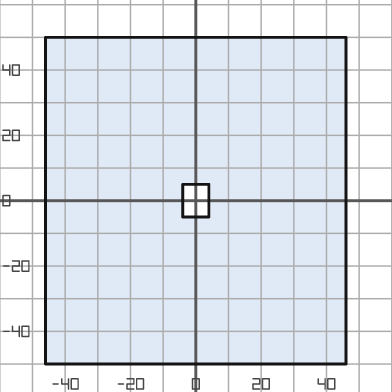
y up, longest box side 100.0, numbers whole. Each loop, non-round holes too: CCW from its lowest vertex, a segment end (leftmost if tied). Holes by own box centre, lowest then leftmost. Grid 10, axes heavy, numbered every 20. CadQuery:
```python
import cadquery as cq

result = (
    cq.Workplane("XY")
    .moveTo(-46.0, -50.0)
    .lineTo(46.0, -50.0)
    .lineTo(46.0, 50.0)
    .lineTo(-46.0, 50.0)
    .close()
    .moveTo(-4.0, -5.0)
    .lineTo(4.0, -5.0)
    .lineTo(4.0, 5.0)
    .lineTo(-4.0, 5.0)
    .close()
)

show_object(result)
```